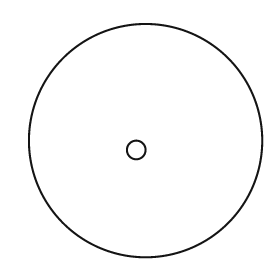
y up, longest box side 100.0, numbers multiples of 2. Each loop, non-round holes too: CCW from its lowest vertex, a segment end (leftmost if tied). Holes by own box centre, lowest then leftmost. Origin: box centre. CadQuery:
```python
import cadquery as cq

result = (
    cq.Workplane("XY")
    .moveTo(0.0, 0.0)
    .circle(50.0)
    .moveTo(-4.0, -4.0)
    .circle(4.0)
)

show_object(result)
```